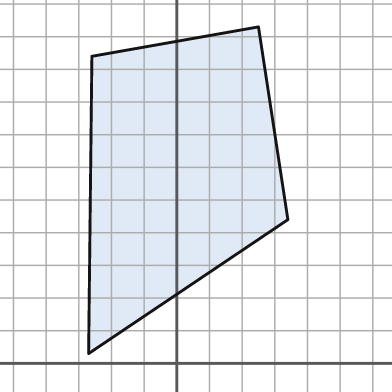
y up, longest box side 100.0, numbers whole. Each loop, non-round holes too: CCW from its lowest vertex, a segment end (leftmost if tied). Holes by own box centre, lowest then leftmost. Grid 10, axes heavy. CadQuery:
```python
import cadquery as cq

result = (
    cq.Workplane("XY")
    .moveTo(-27.0, 3.0)
    .lineTo(34.0, 44.0)
    .lineTo(25.0, 103.0)
    .lineTo(-26.0, 94.0)
    .close()
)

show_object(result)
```